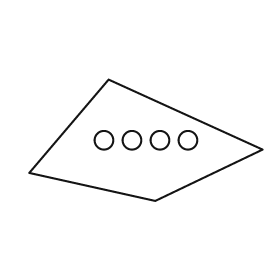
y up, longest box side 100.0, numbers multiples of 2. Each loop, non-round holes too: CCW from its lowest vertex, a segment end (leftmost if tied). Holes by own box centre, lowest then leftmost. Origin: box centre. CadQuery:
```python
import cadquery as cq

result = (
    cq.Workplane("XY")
    .moveTo(4.0, -26.0)
    .lineTo(50.0, -4.0)
    .lineTo(-16.0, 26.0)
    .lineTo(-50.0, -14.0)
    .close()
    .moveTo(-18.0, 0.0)
    .circle(4.0)
    .moveTo(-6.0, 0.0)
    .circle(4.0)
    .moveTo(6.0, 0.0)
    .circle(4.0)
    .moveTo(18.0, 0.0)
    .circle(4.0)
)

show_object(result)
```